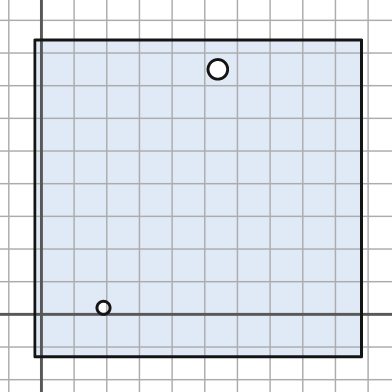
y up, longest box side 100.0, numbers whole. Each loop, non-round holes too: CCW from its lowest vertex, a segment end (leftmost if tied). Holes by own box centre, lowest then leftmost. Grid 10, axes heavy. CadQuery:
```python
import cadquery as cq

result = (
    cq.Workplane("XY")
    .moveTo(-2.0, -13.0)
    .lineTo(98.0, -13.0)
    .lineTo(98.0, 84.0)
    .lineTo(-2.0, 84.0)
    .close()
    .moveTo(19.0, 2.0)
    .circle(2.0)
    .moveTo(54.0, 75.0)
    .circle(3.0)
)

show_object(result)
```